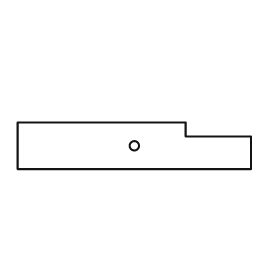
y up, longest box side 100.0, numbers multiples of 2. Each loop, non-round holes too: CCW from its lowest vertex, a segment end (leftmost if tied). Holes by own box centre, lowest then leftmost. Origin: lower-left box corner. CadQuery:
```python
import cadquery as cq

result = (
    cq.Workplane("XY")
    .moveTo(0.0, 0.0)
    .lineTo(100.0, 0.0)
    .lineTo(100.0, 14.0)
    .lineTo(72.0, 14.0)
    .lineTo(72.0, 20.0)
    .lineTo(0.0, 20.0)
    .close()
    .moveTo(50.0, 10.0)
    .circle(2.0)
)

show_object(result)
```